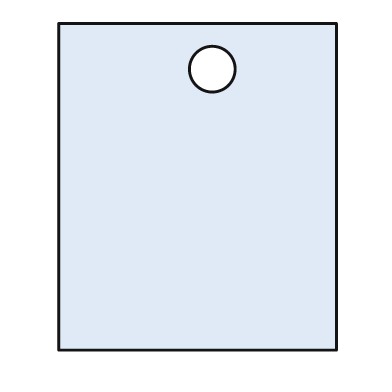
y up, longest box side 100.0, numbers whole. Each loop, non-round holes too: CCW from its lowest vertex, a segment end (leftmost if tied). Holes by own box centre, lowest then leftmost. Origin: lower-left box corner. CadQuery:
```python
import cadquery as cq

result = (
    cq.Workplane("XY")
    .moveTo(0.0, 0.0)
    .lineTo(85.0, 0.0)
    .lineTo(85.0, 100.0)
    .lineTo(0.0, 100.0)
    .close()
    .moveTo(47.0, 86.0)
    .circle(7.0)
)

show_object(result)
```